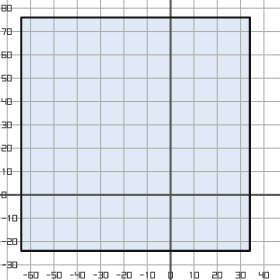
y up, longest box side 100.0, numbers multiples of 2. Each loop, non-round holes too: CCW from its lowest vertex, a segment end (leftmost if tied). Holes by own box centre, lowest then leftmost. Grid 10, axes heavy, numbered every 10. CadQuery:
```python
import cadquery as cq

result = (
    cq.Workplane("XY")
    .moveTo(-64.0, -24.0)
    .lineTo(34.0, -24.0)
    .lineTo(34.0, 76.0)
    .lineTo(-64.0, 76.0)
    .close()
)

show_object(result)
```